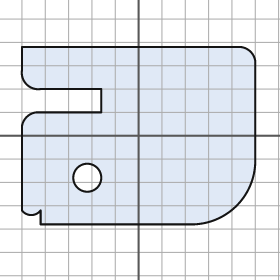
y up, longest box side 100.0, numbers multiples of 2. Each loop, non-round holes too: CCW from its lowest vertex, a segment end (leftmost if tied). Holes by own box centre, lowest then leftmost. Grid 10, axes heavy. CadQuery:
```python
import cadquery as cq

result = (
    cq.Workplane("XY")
    .moveTo(-42.0, -38.0)
    .lineTo(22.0, -38.0)
    .threePointArc((42.0, -30.0), (50.0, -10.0))
    .lineTo(50.0, 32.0)
    .threePointArc((48.0, 36.0), (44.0, 38.0))
    .lineTo(-50.0, 38.0)
    .lineTo(-50.0, 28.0)
    .threePointArc((-48.0, 22.0), (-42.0, 20.0))
    .lineTo(-16.0, 20.0)
    .lineTo(-16.0, 10.0)
    .lineTo(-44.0, 10.0)
    .threePointArc((-48.0, 8.0), (-50.0, 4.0))
    .lineTo(-50.0, -32.0)
    .threePointArc((-46.0, -34.0), (-42.0, -32.0))
    .close()
    .moveTo(-22.0, -18.0)
    .circle(6.0)
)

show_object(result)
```